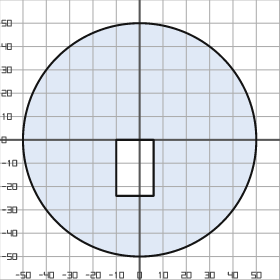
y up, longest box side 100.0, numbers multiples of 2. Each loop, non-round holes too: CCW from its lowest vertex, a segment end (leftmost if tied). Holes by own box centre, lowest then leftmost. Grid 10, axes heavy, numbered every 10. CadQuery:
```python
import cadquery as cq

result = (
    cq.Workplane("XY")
    .moveTo(0.0, 0.0)
    .circle(50.0)
    .moveTo(-10.0, -24.0)
    .lineTo(6.0, -24.0)
    .lineTo(6.0, 0.0)
    .lineTo(-10.0, 0.0)
    .close()
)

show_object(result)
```